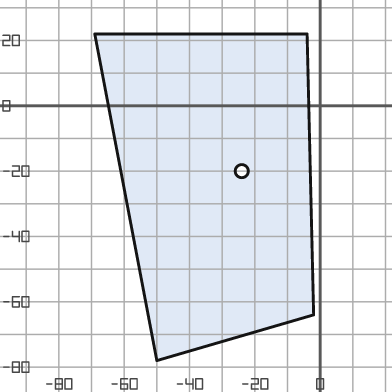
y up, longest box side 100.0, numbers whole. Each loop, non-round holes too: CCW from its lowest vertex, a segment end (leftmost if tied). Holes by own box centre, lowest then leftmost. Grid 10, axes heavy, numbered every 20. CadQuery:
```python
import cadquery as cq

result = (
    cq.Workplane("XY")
    .moveTo(-50.0, -78.0)
    .lineTo(-2.0, -64.0)
    .lineTo(-4.0, 22.0)
    .lineTo(-69.0, 22.0)
    .close()
    .moveTo(-24.0, -20.0)
    .circle(2.0)
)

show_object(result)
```